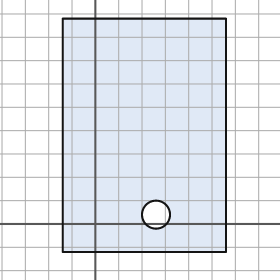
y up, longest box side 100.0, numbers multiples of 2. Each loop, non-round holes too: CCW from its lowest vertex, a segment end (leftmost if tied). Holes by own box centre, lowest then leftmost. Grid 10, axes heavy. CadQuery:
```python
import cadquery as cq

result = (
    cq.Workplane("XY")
    .moveTo(-14.0, -12.0)
    .lineTo(56.0, -12.0)
    .lineTo(56.0, 88.0)
    .lineTo(-14.0, 88.0)
    .close()
    .moveTo(26.0, 4.0)
    .circle(6.0)
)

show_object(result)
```